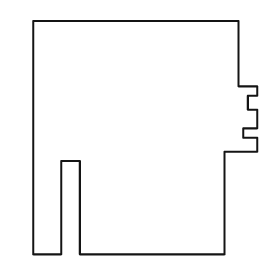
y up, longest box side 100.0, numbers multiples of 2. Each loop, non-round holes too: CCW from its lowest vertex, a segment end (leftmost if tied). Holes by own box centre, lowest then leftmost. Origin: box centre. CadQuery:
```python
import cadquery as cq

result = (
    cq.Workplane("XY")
    .moveTo(-48.0, -50.0)
    .lineTo(-36.0, -50.0)
    .lineTo(-36.0, -10.0)
    .lineTo(-28.0, -10.0)
    .lineTo(-28.0, -50.0)
    .lineTo(34.0, -50.0)
    .lineTo(34.0, -6.0)
    .lineTo(48.0, -6.0)
    .lineTo(48.0, 0.0)
    .lineTo(42.0, 0.0)
    .lineTo(42.0, 4.0)
    .lineTo(48.0, 4.0)
    .lineTo(48.0, 12.0)
    .lineTo(44.0, 12.0)
    .lineTo(44.0, 18.0)
    .lineTo(48.0, 18.0)
    .lineTo(48.0, 22.0)
    .lineTo(40.0, 22.0)
    .lineTo(40.0, 50.0)
    .lineTo(-48.0, 50.0)
    .close()
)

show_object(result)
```